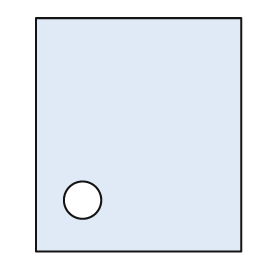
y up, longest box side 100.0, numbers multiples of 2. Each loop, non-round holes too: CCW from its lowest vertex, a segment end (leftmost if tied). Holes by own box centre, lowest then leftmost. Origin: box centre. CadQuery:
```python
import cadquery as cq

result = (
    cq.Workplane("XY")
    .moveTo(-44.0, -50.0)
    .lineTo(44.0, -50.0)
    .lineTo(44.0, 50.0)
    .lineTo(-44.0, 50.0)
    .close()
    .moveTo(-24.0, -28.0)
    .circle(8.0)
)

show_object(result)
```